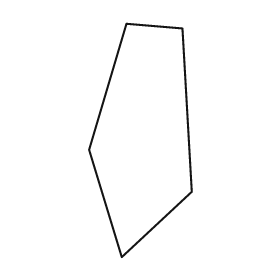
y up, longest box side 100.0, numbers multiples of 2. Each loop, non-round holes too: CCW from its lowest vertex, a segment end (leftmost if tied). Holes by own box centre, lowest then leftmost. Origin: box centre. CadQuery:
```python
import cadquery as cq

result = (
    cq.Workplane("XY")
    .moveTo(-8.0, -50.0)
    .lineTo(22.0, -22.0)
    .lineTo(18.0, 48.0)
    .lineTo(-6.0, 50.0)
    .lineTo(-22.0, -4.0)
    .close()
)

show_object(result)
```